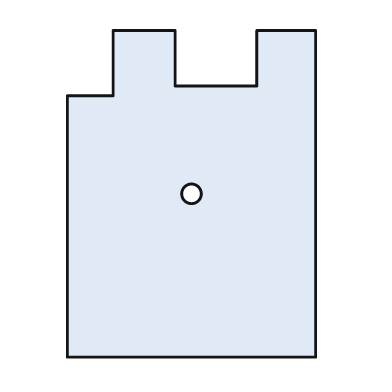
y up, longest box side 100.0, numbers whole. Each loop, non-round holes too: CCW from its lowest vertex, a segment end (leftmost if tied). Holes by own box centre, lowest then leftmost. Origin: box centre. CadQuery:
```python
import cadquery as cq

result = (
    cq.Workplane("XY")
    .moveTo(-38.0, -50.0)
    .lineTo(38.0, -50.0)
    .lineTo(38.0, 50.0)
    .lineTo(20.0, 50.0)
    .lineTo(20.0, 33.0)
    .lineTo(-5.0, 33.0)
    .lineTo(-5.0, 50.0)
    .lineTo(-24.0, 50.0)
    .lineTo(-24.0, 30.0)
    .lineTo(-38.0, 30.0)
    .close()
    .moveTo(0.0, 0.0)
    .circle(3.0)
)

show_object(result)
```